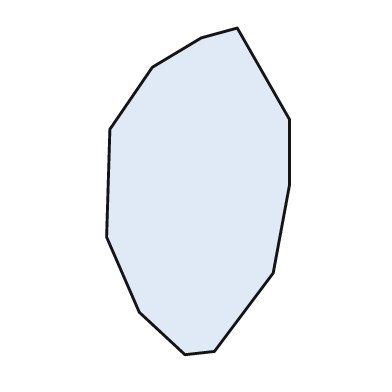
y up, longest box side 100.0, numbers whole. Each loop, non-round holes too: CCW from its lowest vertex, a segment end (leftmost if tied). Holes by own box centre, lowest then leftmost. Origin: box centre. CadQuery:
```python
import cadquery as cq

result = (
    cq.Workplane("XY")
    .moveTo(-4.0, -50.0)
    .lineTo(5.0, -49.0)
    .lineTo(23.0, -25.0)
    .lineTo(28.0, 2.0)
    .lineTo(28.0, 22.0)
    .lineTo(12.0, 50.0)
    .lineTo(1.0, 47.0)
    .lineTo(-14.0, 38.0)
    .lineTo(-27.0, 19.0)
    .lineTo(-28.0, -14.0)
    .lineTo(-18.0, -37.0)
    .close()
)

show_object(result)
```